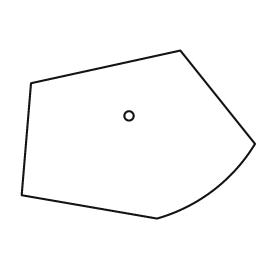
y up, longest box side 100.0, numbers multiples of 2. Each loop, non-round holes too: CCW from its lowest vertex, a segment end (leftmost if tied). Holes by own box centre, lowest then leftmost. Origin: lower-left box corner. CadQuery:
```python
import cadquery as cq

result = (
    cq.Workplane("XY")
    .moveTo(58.0, 0.0)
    .threePointArc((82.0, 12.0), (100.0, 32.0))
    .lineTo(68.0, 72.0)
    .lineTo(4.0, 58.0)
    .lineTo(0.0, 10.0)
    .close()
    .moveTo(46.0, 44.0)
    .circle(2.0)
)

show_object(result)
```